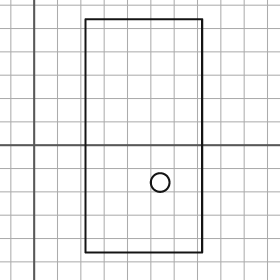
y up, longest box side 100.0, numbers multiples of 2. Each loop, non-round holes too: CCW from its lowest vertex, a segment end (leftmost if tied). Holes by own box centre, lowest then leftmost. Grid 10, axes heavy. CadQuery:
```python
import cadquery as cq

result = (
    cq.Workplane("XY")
    .moveTo(22.0, -46.0)
    .lineTo(72.0, -46.0)
    .lineTo(72.0, 54.0)
    .lineTo(22.0, 54.0)
    .close()
    .moveTo(54.0, -16.0)
    .circle(4.0)
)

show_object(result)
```